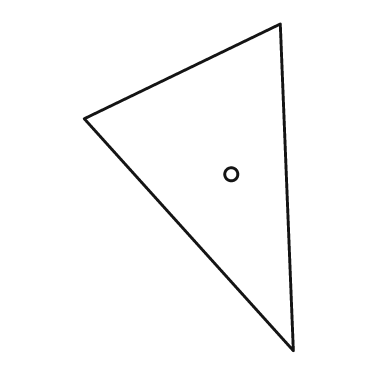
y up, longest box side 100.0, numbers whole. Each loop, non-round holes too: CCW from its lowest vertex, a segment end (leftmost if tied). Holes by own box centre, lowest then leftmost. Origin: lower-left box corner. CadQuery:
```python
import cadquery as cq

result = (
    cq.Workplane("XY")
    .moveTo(64.0, 0.0)
    .lineTo(60.0, 100.0)
    .lineTo(0.0, 71.0)
    .close()
    .moveTo(45.0, 54.0)
    .circle(2.0)
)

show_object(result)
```